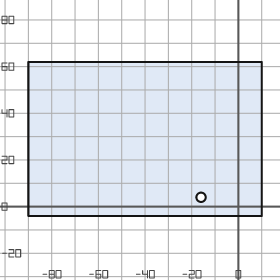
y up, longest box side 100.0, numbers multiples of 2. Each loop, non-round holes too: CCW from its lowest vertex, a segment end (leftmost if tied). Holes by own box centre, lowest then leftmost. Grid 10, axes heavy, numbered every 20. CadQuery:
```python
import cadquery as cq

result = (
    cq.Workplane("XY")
    .moveTo(-90.0, -4.0)
    .lineTo(10.0, -4.0)
    .lineTo(10.0, 62.0)
    .lineTo(-90.0, 62.0)
    .close()
    .moveTo(-16.0, 4.0)
    .circle(2.0)
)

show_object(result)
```